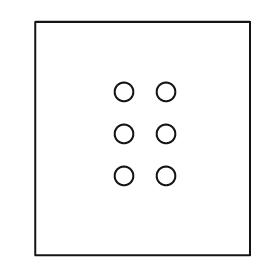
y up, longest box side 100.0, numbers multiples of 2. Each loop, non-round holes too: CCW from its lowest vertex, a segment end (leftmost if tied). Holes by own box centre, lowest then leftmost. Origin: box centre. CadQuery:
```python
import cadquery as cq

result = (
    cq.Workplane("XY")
    .moveTo(-46.0, -50.0)
    .lineTo(46.0, -50.0)
    .lineTo(46.0, 50.0)
    .lineTo(-46.0, 50.0)
    .close()
    .moveTo(-8.0, -16.0)
    .circle(4.0)
    .moveTo(10.0, -16.0)
    .circle(4.0)
    .moveTo(-8.0, 2.0)
    .circle(4.0)
    .moveTo(10.0, 2.0)
    .circle(4.0)
    .moveTo(-8.0, 20.0)
    .circle(4.0)
    .moveTo(10.0, 20.0)
    .circle(4.0)
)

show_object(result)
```